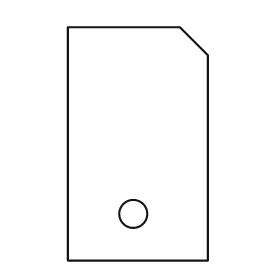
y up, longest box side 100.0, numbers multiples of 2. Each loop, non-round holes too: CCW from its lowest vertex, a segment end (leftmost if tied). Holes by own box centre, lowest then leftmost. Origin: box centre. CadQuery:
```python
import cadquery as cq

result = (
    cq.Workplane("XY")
    .moveTo(-30.0, -50.0)
    .lineTo(30.0, -50.0)
    .lineTo(30.0, 38.0)
    .lineTo(18.0, 50.0)
    .lineTo(-30.0, 50.0)
    .close()
    .moveTo(-2.0, -30.0)
    .circle(6.0)
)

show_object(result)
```